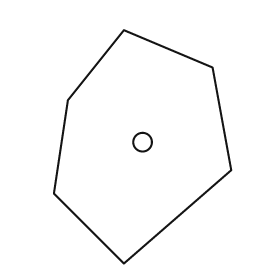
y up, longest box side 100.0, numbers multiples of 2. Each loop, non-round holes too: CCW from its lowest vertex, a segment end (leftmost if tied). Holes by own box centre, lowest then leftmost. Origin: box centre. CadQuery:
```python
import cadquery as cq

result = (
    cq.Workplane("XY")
    .moveTo(-8.0, -50.0)
    .lineTo(38.0, -10.0)
    .lineTo(30.0, 34.0)
    .lineTo(-8.0, 50.0)
    .lineTo(-32.0, 20.0)
    .lineTo(-38.0, -20.0)
    .close()
    .moveTo(0.0, 2.0)
    .circle(4.0)
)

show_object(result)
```